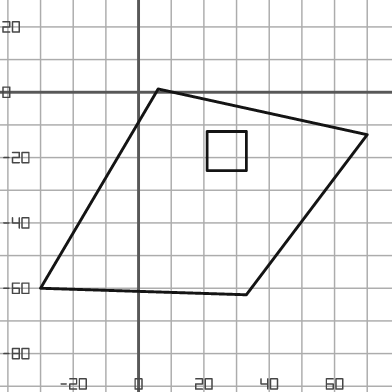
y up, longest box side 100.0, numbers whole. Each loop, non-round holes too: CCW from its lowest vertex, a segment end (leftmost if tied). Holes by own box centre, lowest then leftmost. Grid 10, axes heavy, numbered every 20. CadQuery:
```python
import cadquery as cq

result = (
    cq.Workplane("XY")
    .moveTo(33.0, -62.0)
    .lineTo(70.0, -13.0)
    .lineTo(6.0, 1.0)
    .lineTo(-30.0, -60.0)
    .close()
    .moveTo(21.0, -24.0)
    .lineTo(33.0, -24.0)
    .lineTo(33.0, -12.0)
    .lineTo(21.0, -12.0)
    .close()
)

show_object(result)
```